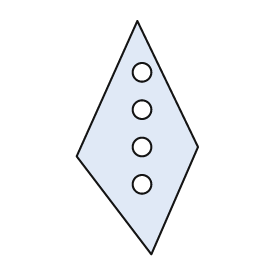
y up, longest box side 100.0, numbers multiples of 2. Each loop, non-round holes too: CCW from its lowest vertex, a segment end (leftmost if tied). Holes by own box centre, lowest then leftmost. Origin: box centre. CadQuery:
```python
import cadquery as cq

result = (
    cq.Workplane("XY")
    .moveTo(6.0, -50.0)
    .lineTo(26.0, -4.0)
    .lineTo(0.0, 50.0)
    .lineTo(-26.0, -8.0)
    .close()
    .moveTo(2.0, -20.0)
    .circle(4.0)
    .moveTo(2.0, -4.0)
    .circle(4.0)
    .moveTo(2.0, 12.0)
    .circle(4.0)
    .moveTo(2.0, 28.0)
    .circle(4.0)
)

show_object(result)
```